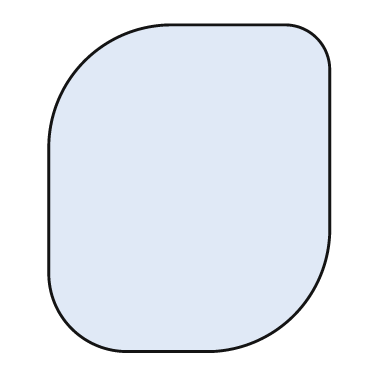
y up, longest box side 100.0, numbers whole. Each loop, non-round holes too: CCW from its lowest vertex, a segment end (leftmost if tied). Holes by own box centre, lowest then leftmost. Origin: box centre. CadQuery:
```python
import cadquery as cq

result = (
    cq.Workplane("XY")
    .moveTo(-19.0, -50.0)
    .lineTo(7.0, -50.0)
    .threePointArc((32.0, -39.0), (43.0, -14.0))
    .lineTo(43.0, 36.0)
    .threePointArc((39.0, 46.0), (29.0, 50.0))
    .lineTo(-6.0, 50.0)
    .threePointArc((-32.0, 39.0), (-43.0, 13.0))
    .lineTo(-43.0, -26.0)
    .threePointArc((-36.0, -43.0), (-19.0, -50.0))
    .close()
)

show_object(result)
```